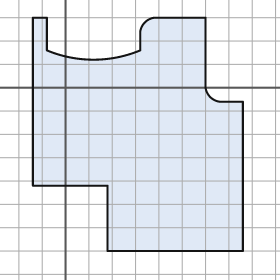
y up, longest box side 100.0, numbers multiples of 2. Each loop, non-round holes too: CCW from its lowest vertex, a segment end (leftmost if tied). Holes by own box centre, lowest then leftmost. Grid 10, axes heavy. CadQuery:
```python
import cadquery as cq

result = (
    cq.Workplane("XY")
    .moveTo(18.0, -70.0)
    .lineTo(76.0, -70.0)
    .lineTo(76.0, -6.0)
    .lineTo(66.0, -6.0)
    .threePointArc((62.0, -4.0), (60.0, 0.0))
    .lineTo(60.0, 30.0)
    .lineTo(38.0, 30.0)
    .threePointArc((34.0, 28.0), (32.0, 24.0))
    .lineTo(32.0, 16.0)
    .threePointArc((12.0, 12.0), (-8.0, 16.0))
    .lineTo(-8.0, 30.0)
    .lineTo(-14.0, 30.0)
    .lineTo(-14.0, -42.0)
    .lineTo(18.0, -42.0)
    .close()
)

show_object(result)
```